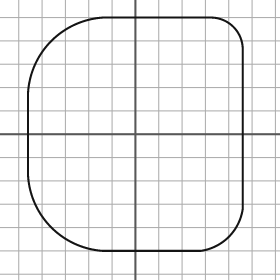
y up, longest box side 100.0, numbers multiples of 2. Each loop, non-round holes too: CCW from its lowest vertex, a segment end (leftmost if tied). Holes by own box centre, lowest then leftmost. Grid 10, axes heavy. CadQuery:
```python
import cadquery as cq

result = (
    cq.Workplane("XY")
    .moveTo(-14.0, -50.0)
    .lineTo(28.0, -50.0)
    .threePointArc((40.0, -44.0), (46.0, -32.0))
    .lineTo(46.0, 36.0)
    .threePointArc((42.0, 46.0), (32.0, 50.0))
    .lineTo(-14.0, 50.0)
    .threePointArc((-36.0, 40.0), (-46.0, 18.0))
    .lineTo(-46.0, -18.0)
    .threePointArc((-36.0, -40.0), (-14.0, -50.0))
    .close()
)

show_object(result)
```